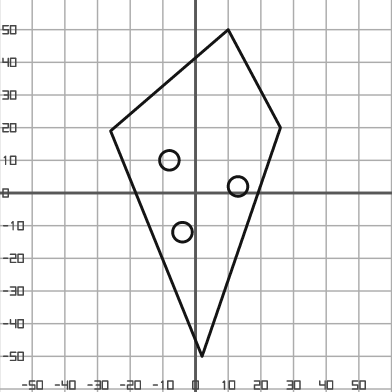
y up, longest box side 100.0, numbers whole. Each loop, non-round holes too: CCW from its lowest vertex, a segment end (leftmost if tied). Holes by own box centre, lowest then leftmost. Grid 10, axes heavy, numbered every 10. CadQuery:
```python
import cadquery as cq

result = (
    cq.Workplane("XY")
    .moveTo(2.0, -50.0)
    .lineTo(26.0, 20.0)
    .lineTo(10.0, 50.0)
    .lineTo(-26.0, 19.0)
    .close()
    .moveTo(-4.0, -12.0)
    .circle(3.0)
    .moveTo(13.0, 2.0)
    .circle(3.0)
    .moveTo(-8.0, 10.0)
    .circle(3.0)
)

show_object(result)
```